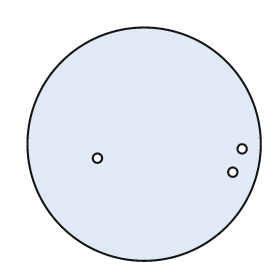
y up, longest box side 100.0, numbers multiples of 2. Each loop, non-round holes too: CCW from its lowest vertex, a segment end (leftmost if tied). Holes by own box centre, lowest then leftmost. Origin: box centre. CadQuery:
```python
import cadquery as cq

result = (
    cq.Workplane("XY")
    .moveTo(0.0, 0.0)
    .circle(50.0)
    .moveTo(38.0, -12.0)
    .circle(2.0)
    .moveTo(-20.0, -6.0)
    .circle(2.0)
    .moveTo(42.0, -2.0)
    .circle(2.0)
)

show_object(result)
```